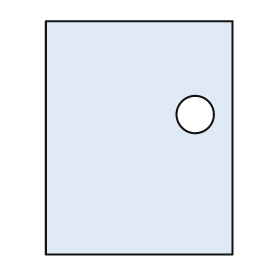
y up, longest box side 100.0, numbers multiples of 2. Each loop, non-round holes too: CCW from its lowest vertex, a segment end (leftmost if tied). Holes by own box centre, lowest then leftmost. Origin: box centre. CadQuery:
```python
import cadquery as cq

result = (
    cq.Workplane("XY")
    .moveTo(-40.0, -50.0)
    .lineTo(40.0, -50.0)
    .lineTo(40.0, 50.0)
    .lineTo(-40.0, 50.0)
    .close()
    .moveTo(24.0, 10.0)
    .circle(8.0)
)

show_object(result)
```